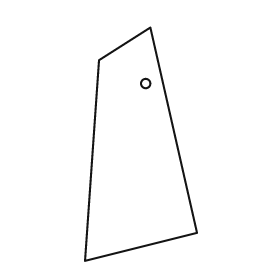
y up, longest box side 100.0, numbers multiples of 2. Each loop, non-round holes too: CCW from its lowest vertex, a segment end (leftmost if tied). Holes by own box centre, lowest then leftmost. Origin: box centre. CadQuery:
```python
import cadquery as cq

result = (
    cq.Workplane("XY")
    .moveTo(-24.0, -50.0)
    .lineTo(24.0, -38.0)
    .lineTo(4.0, 50.0)
    .lineTo(-18.0, 36.0)
    .close()
    .moveTo(2.0, 26.0)
    .circle(2.0)
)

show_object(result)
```